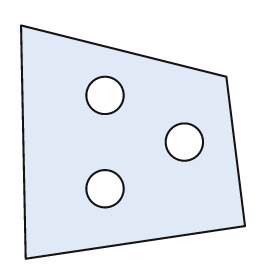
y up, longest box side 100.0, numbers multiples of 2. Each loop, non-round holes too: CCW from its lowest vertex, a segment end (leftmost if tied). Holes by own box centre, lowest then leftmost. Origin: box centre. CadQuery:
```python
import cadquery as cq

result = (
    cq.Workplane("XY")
    .moveTo(-46.0, -50.0)
    .lineTo(48.0, -36.0)
    .lineTo(40.0, 28.0)
    .lineTo(-48.0, 50.0)
    .close()
    .moveTo(-12.0, -20.0)
    .circle(8.0)
    .moveTo(22.0, 0.0)
    .circle(8.0)
    .moveTo(-12.0, 20.0)
    .circle(8.0)
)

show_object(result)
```